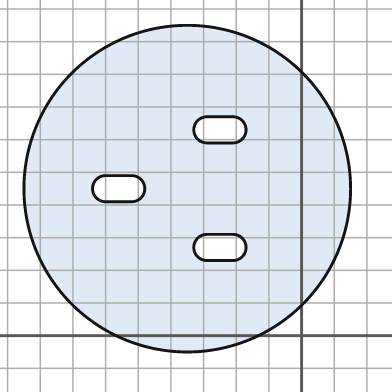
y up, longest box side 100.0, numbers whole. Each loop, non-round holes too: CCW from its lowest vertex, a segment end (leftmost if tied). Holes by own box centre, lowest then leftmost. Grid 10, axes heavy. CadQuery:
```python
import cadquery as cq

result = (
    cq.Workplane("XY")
    .moveTo(-35.0, 45.0)
    .circle(50.0)
    .moveTo(-29.0, 23.0)
    .lineTo(-21.0, 23.0)
    .threePointArc((-17.0, 27.0), (-21.0, 31.0))
    .lineTo(-29.0, 31.0)
    .threePointArc((-33.0, 27.0), (-29.0, 23.0))
    .close()
    .moveTo(-60.0, 41.0)
    .lineTo(-52.0, 41.0)
    .threePointArc((-48.0, 45.0), (-52.0, 49.0))
    .lineTo(-60.0, 49.0)
    .threePointArc((-64.0, 45.0), (-60.0, 41.0))
    .close()
    .moveTo(-29.0, 59.0)
    .lineTo(-21.0, 59.0)
    .threePointArc((-17.0, 63.0), (-21.0, 67.0))
    .lineTo(-29.0, 67.0)
    .threePointArc((-33.0, 63.0), (-29.0, 59.0))
    .close()
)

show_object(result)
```